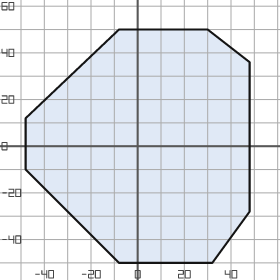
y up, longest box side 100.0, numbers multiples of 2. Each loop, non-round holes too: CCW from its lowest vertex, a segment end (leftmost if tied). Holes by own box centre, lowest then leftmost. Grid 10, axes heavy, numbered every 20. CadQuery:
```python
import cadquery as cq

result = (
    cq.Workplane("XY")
    .moveTo(-8.0, -50.0)
    .lineTo(32.0, -50.0)
    .lineTo(48.0, -28.0)
    .lineTo(48.0, 36.0)
    .lineTo(30.0, 50.0)
    .lineTo(-8.0, 50.0)
    .lineTo(-48.0, 12.0)
    .lineTo(-48.0, -10.0)
    .close()
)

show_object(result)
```